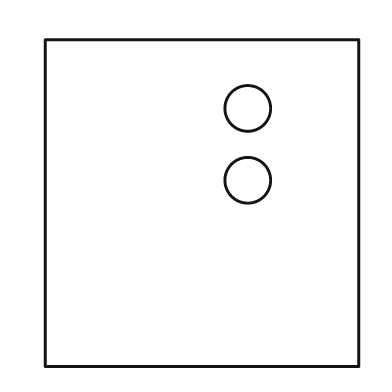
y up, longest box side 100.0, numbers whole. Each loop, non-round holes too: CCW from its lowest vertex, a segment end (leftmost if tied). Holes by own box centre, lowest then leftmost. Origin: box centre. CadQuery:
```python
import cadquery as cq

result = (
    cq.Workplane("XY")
    .moveTo(-48.0, -50.0)
    .lineTo(48.0, -50.0)
    .lineTo(48.0, 50.0)
    .lineTo(-48.0, 50.0)
    .close()
    .moveTo(14.0, 7.0)
    .circle(7.0)
    .moveTo(14.0, 29.0)
    .circle(7.0)
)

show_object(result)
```